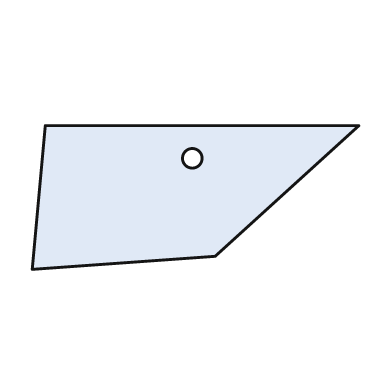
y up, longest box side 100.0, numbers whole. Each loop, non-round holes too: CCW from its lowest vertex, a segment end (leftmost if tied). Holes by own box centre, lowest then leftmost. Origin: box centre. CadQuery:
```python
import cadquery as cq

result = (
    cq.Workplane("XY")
    .moveTo(-50.0, -22.0)
    .lineTo(6.0, -18.0)
    .lineTo(50.0, 22.0)
    .lineTo(-46.0, 22.0)
    .close()
    .moveTo(-1.0, 12.0)
    .circle(3.0)
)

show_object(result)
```